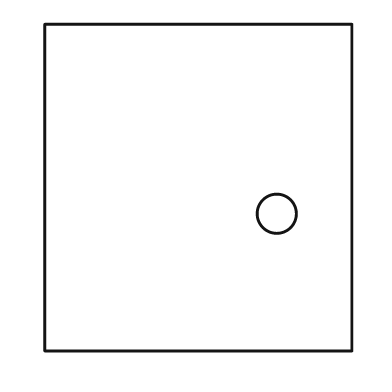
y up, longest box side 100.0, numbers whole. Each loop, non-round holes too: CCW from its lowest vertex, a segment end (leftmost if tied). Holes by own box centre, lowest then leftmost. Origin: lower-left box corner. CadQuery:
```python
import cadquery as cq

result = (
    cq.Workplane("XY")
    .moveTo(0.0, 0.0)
    .lineTo(94.0, 0.0)
    .lineTo(94.0, 100.0)
    .lineTo(0.0, 100.0)
    .close()
    .moveTo(71.0, 42.0)
    .circle(6.0)
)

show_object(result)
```